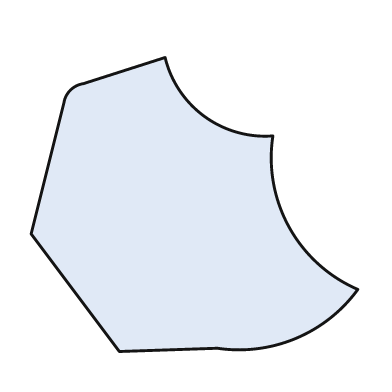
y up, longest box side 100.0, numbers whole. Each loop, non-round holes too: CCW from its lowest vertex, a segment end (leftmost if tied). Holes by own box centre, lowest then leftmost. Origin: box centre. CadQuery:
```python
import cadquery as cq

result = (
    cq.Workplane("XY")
    .moveTo(-23.0, -45.0)
    .lineTo(7.0, -44.0)
    .threePointArc((31.0, -41.0), (50.0, -26.0))
    .threePointArc((29.0, -7.0), (24.0, 21.0))
    .threePointArc((3.0, 27.0), (-9.0, 45.0))
    .lineTo(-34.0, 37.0)
    .threePointArc((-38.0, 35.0), (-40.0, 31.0))
    .lineTo(-50.0, -9.0)
    .close()
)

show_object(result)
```